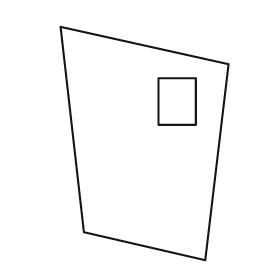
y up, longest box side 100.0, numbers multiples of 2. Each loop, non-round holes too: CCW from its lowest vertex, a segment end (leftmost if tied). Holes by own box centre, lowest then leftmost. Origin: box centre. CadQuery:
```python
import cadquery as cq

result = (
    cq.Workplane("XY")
    .moveTo(26.0, -50.0)
    .lineTo(36.0, 34.0)
    .lineTo(-36.0, 50.0)
    .lineTo(-26.0, -38.0)
    .close()
    .moveTo(6.0, 8.0)
    .lineTo(22.0, 8.0)
    .lineTo(22.0, 28.0)
    .lineTo(6.0, 28.0)
    .close()
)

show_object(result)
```